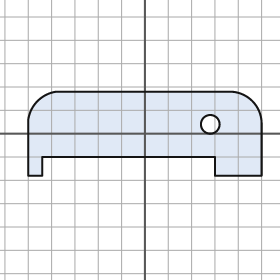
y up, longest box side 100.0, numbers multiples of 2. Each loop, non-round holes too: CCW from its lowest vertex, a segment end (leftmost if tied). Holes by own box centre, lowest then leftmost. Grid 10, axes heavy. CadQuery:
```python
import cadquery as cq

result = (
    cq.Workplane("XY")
    .moveTo(-50.0, -18.0)
    .lineTo(-44.0, -18.0)
    .lineTo(-44.0, -10.0)
    .lineTo(30.0, -10.0)
    .lineTo(30.0, -18.0)
    .lineTo(50.0, -18.0)
    .lineTo(50.0, 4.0)
    .threePointArc((46.0, 14.0), (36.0, 18.0))
    .lineTo(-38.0, 18.0)
    .threePointArc((-46.0, 14.0), (-50.0, 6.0))
    .close()
    .moveTo(28.0, 4.0)
    .circle(4.0)
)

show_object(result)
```